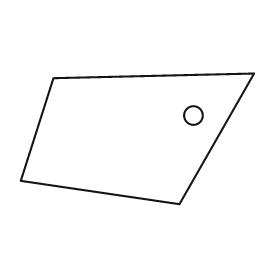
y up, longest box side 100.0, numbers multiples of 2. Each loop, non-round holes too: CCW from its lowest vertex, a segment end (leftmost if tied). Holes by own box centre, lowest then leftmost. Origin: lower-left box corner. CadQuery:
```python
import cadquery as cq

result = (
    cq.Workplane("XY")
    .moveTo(68.0, 0.0)
    .lineTo(100.0, 56.0)
    .lineTo(14.0, 54.0)
    .lineTo(0.0, 10.0)
    .close()
    .moveTo(74.0, 38.0)
    .circle(4.0)
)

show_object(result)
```